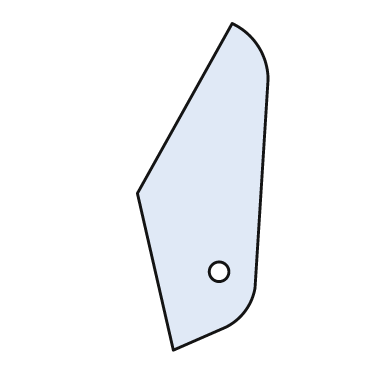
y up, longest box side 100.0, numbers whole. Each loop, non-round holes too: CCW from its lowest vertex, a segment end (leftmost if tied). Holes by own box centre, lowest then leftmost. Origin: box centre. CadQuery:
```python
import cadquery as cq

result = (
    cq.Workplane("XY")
    .moveTo(-9.0, -50.0)
    .lineTo(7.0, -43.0)
    .threePointArc((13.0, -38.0), (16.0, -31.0))
    .lineTo(20.0, 33.0)
    .threePointArc((17.0, 43.0), (9.0, 50.0))
    .lineTo(-20.0, -2.0)
    .close()
    .moveTo(5.0, -26.0)
    .circle(3.0)
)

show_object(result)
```